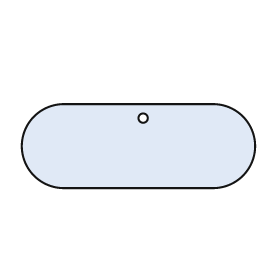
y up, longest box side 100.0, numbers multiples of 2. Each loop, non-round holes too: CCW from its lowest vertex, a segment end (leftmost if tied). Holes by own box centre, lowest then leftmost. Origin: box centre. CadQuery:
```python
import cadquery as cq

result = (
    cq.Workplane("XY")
    .moveTo(-32.0, -18.0)
    .lineTo(32.0, -18.0)
    .threePointArc((50.0, 0.0), (32.0, 18.0))
    .lineTo(-32.0, 18.0)
    .threePointArc((-50.0, 0.0), (-32.0, -18.0))
    .close()
    .moveTo(2.0, 12.0)
    .circle(2.0)
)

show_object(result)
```